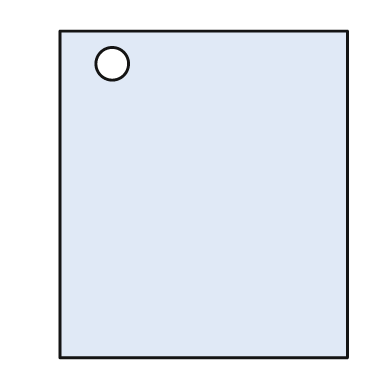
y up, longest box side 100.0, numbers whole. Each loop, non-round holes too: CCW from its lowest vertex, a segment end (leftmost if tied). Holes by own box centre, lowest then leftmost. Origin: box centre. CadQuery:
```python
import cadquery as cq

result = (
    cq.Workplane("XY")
    .moveTo(-44.0, -50.0)
    .lineTo(44.0, -50.0)
    .lineTo(44.0, 50.0)
    .lineTo(-44.0, 50.0)
    .close()
    .moveTo(-28.0, 40.0)
    .circle(5.0)
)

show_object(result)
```